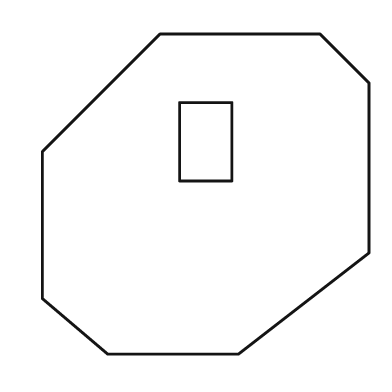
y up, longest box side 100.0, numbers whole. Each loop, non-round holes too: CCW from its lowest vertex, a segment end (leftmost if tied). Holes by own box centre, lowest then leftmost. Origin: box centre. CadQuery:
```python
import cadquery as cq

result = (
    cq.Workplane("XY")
    .moveTo(-30.0, -49.0)
    .lineTo(10.0, -49.0)
    .lineTo(50.0, -18.0)
    .lineTo(50.0, 34.0)
    .lineTo(35.0, 49.0)
    .lineTo(-14.0, 49.0)
    .lineTo(-50.0, 13.0)
    .lineTo(-50.0, -32.0)
    .close()
    .moveTo(-8.0, 4.0)
    .lineTo(8.0, 4.0)
    .lineTo(8.0, 28.0)
    .lineTo(-8.0, 28.0)
    .close()
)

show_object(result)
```